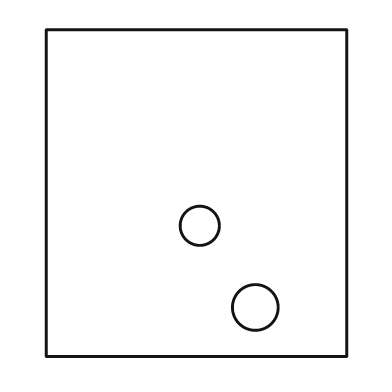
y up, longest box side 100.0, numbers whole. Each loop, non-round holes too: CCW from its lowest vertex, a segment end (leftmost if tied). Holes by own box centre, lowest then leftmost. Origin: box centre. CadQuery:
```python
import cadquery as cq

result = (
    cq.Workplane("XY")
    .moveTo(-46.0, -50.0)
    .lineTo(46.0, -50.0)
    .lineTo(46.0, 50.0)
    .lineTo(-46.0, 50.0)
    .close()
    .moveTo(18.0, -35.0)
    .circle(7.0)
    .moveTo(1.0, -10.0)
    .circle(6.0)
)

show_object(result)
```